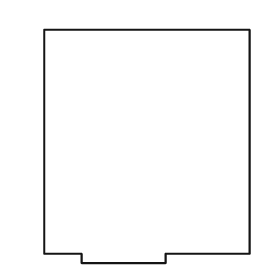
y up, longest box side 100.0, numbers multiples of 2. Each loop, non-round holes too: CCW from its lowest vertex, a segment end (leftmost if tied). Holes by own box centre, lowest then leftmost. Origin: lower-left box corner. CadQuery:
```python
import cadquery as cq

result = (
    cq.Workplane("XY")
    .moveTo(16.0, 0.0)
    .lineTo(52.0, 0.0)
    .lineTo(52.0, 4.0)
    .lineTo(88.0, 4.0)
    .lineTo(88.0, 100.0)
    .lineTo(0.0, 100.0)
    .lineTo(0.0, 4.0)
    .lineTo(16.0, 4.0)
    .close()
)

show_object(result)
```